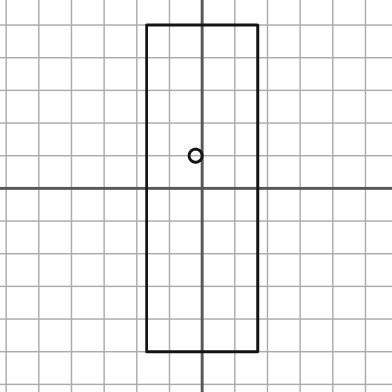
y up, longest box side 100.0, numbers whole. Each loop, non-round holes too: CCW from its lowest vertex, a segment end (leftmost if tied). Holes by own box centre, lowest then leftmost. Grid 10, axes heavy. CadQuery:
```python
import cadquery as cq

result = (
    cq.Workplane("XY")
    .moveTo(-17.0, -50.0)
    .lineTo(17.0, -50.0)
    .lineTo(17.0, 50.0)
    .lineTo(-17.0, 50.0)
    .close()
    .moveTo(-2.0, 10.0)
    .circle(2.0)
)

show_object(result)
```